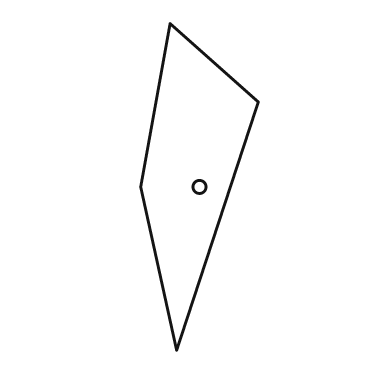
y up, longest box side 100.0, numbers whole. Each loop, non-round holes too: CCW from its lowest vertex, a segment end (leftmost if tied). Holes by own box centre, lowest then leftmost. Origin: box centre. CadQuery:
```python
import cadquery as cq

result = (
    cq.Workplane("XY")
    .moveTo(-7.0, -50.0)
    .lineTo(18.0, 26.0)
    .lineTo(-9.0, 50.0)
    .lineTo(-18.0, 0.0)
    .close()
    .moveTo(0.0, 0.0)
    .circle(2.0)
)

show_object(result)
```